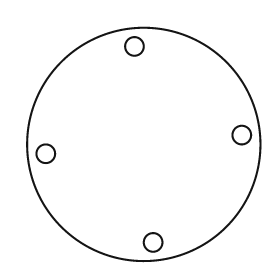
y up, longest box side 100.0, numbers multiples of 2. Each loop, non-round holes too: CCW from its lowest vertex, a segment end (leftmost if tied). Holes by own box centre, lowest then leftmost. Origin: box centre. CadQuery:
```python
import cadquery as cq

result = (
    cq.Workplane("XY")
    .moveTo(0.0, 0.0)
    .circle(50.0)
    .moveTo(4.0, -42.0)
    .circle(4.0)
    .moveTo(-42.0, -4.0)
    .circle(4.0)
    .moveTo(42.0, 4.0)
    .circle(4.0)
    .moveTo(-4.0, 42.0)
    .circle(4.0)
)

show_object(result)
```